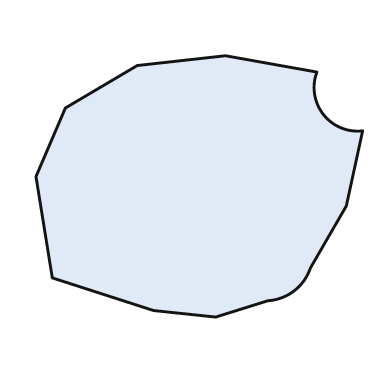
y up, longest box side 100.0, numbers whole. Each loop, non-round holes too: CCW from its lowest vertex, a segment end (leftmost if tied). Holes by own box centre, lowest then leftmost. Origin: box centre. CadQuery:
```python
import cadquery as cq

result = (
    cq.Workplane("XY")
    .moveTo(5.0, -40.0)
    .lineTo(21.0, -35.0)
    .threePointArc((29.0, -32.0), (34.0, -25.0))
    .lineTo(45.0, -6.0)
    .lineTo(50.0, 17.0)
    .threePointArc((38.0, 22.0), (36.0, 35.0))
    .lineTo(8.0, 40.0)
    .lineTo(-19.0, 37.0)
    .lineTo(-41.0, 24.0)
    .lineTo(-50.0, 3.0)
    .lineTo(-45.0, -28.0)
    .lineTo(-14.0, -38.0)
    .close()
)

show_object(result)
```